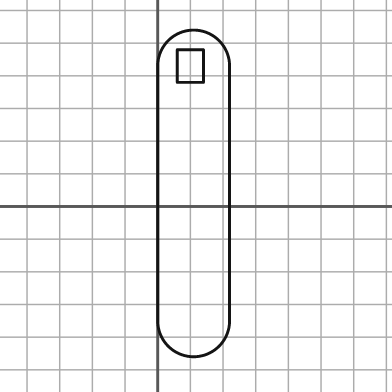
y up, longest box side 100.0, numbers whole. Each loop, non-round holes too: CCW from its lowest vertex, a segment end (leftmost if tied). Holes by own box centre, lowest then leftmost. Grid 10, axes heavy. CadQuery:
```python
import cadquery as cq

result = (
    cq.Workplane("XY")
    .moveTo(0.0, -35.0)
    .threePointArc((11.0, -46.0), (22.0, -35.0))
    .lineTo(22.0, 43.0)
    .threePointArc((11.0, 54.0), (0.0, 43.0))
    .close()
    .moveTo(6.0, 38.0)
    .lineTo(14.0, 38.0)
    .lineTo(14.0, 48.0)
    .lineTo(6.0, 48.0)
    .close()
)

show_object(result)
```